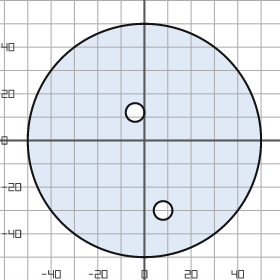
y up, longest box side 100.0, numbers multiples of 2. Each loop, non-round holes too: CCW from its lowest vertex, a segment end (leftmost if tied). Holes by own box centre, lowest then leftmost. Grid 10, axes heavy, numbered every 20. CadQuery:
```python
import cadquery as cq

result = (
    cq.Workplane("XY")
    .moveTo(0.0, 0.0)
    .circle(50.0)
    .moveTo(8.0, -30.0)
    .circle(4.0)
    .moveTo(-4.0, 12.0)
    .circle(4.0)
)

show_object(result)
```